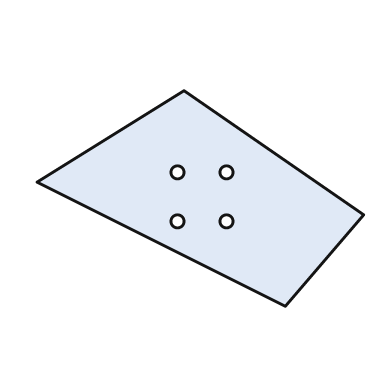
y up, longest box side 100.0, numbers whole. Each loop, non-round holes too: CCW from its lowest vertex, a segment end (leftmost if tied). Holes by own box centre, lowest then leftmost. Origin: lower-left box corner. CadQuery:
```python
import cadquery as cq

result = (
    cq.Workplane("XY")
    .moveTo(76.0, 0.0)
    .lineTo(100.0, 28.0)
    .lineTo(45.0, 66.0)
    .lineTo(0.0, 38.0)
    .close()
    .moveTo(43.0, 26.0)
    .circle(2.0)
    .moveTo(58.0, 26.0)
    .circle(2.0)
    .moveTo(43.0, 41.0)
    .circle(2.0)
    .moveTo(58.0, 41.0)
    .circle(2.0)
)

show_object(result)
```